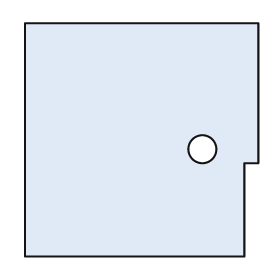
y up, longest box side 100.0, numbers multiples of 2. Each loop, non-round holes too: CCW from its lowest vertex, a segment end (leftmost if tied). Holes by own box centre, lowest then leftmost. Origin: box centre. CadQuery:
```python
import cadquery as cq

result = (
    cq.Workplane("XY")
    .moveTo(-50.0, -50.0)
    .lineTo(44.0, -50.0)
    .lineTo(44.0, -10.0)
    .lineTo(50.0, -10.0)
    .lineTo(50.0, 50.0)
    .lineTo(-50.0, 50.0)
    .close()
    .moveTo(26.0, -4.0)
    .circle(6.0)
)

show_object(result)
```